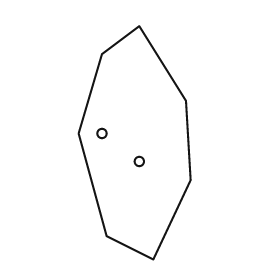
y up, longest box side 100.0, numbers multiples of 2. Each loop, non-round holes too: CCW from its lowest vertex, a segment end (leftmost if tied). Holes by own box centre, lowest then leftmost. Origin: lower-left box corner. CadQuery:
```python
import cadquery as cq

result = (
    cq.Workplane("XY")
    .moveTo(32.0, 0.0)
    .lineTo(48.0, 34.0)
    .lineTo(46.0, 68.0)
    .lineTo(26.0, 100.0)
    .lineTo(10.0, 88.0)
    .lineTo(0.0, 54.0)
    .lineTo(12.0, 10.0)
    .close()
    .moveTo(26.0, 42.0)
    .circle(2.0)
    .moveTo(10.0, 54.0)
    .circle(2.0)
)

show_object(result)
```